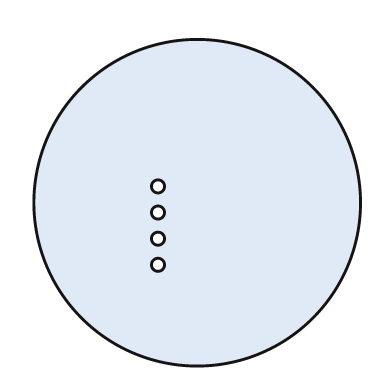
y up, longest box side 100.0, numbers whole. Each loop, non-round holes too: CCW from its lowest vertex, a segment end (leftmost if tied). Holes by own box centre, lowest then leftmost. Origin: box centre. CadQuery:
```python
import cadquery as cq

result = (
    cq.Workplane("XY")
    .moveTo(0.0, 0.0)
    .circle(50.0)
    .moveTo(-12.0, -19.0)
    .circle(2.0)
    .moveTo(-12.0, -11.0)
    .circle(2.0)
    .moveTo(-12.0, -3.0)
    .circle(2.0)
    .moveTo(-12.0, 5.0)
    .circle(2.0)
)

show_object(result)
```